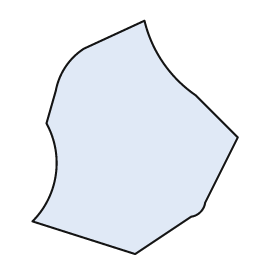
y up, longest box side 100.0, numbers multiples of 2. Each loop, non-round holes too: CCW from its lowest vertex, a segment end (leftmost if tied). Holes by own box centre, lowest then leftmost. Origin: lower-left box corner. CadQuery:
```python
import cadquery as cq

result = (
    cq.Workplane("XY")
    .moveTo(44.0, 0.0)
    .lineTo(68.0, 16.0)
    .threePointArc((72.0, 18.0), (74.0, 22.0))
    .lineTo(88.0, 50.0)
    .lineTo(70.0, 68.0)
    .threePointArc((56.0, 82.0), (48.0, 100.0))
    .lineTo(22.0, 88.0)
    .threePointArc((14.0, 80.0), (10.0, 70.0))
    .lineTo(6.0, 56.0)
    .threePointArc((10.0, 34.0), (0.0, 14.0))
    .close()
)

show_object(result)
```